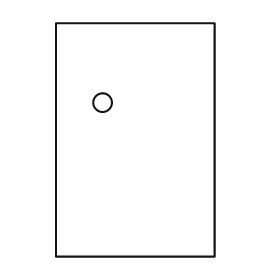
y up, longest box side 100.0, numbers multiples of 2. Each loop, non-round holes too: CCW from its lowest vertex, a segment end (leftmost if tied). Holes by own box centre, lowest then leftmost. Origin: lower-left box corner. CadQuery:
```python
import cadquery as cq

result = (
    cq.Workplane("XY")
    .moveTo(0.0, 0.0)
    .lineTo(68.0, 0.0)
    .lineTo(68.0, 100.0)
    .lineTo(0.0, 100.0)
    .close()
    .moveTo(20.0, 66.0)
    .circle(4.0)
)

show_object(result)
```